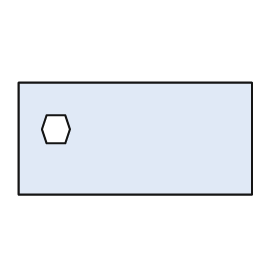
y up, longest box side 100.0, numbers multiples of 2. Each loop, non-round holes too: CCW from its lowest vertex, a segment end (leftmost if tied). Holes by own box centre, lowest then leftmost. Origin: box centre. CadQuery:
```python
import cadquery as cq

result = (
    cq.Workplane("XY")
    .moveTo(-50.0, -24.0)
    .lineTo(50.0, -24.0)
    .lineTo(50.0, 24.0)
    .lineTo(-50.0, 24.0)
    .close()
    .moveTo(-38.0, -2.0)
    .lineTo(-30.0, -2.0)
    .lineTo(-28.0, 4.0)
    .lineTo(-30.0, 10.0)
    .lineTo(-38.0, 10.0)
    .lineTo(-40.0, 4.0)
    .close()
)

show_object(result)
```